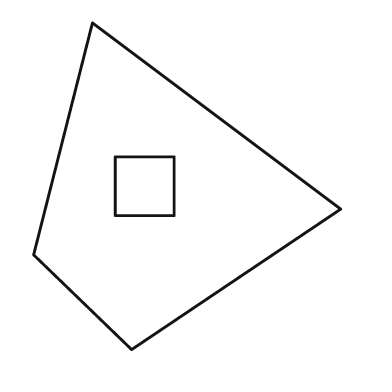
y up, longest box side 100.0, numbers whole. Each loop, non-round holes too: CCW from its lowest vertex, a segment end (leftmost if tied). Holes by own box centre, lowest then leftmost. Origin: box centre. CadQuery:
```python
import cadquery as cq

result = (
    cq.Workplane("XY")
    .moveTo(-17.0, -50.0)
    .lineTo(47.0, -7.0)
    .lineTo(-29.0, 50.0)
    .lineTo(-47.0, -21.0)
    .close()
    .moveTo(-22.0, -9.0)
    .lineTo(-4.0, -9.0)
    .lineTo(-4.0, 9.0)
    .lineTo(-22.0, 9.0)
    .close()
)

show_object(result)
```